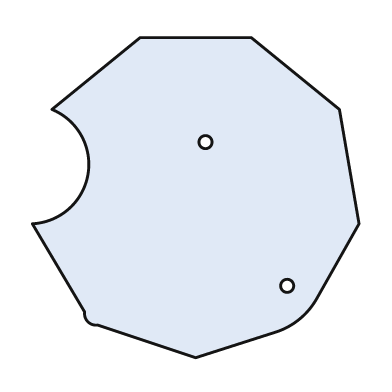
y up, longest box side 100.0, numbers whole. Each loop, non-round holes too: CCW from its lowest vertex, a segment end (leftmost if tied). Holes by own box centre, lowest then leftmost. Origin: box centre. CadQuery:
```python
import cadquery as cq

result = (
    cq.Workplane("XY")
    .moveTo(0.0, -49.0)
    .lineTo(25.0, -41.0)
    .threePointArc((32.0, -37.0), (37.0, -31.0))
    .lineTo(50.0, -8.0)
    .lineTo(44.0, 27.0)
    .lineTo(17.0, 49.0)
    .lineTo(-17.0, 49.0)
    .lineTo(-44.0, 27.0)
    .threePointArc((-33.0, 7.0), (-50.0, -8.0))
    .lineTo(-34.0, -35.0)
    .threePointArc((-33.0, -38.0), (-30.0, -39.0))
    .close()
    .moveTo(28.0, -27.0)
    .circle(2.0)
    .moveTo(3.0, 17.0)
    .circle(2.0)
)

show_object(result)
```